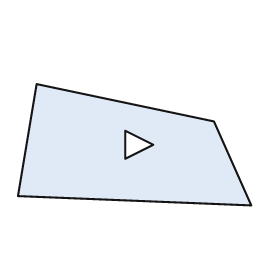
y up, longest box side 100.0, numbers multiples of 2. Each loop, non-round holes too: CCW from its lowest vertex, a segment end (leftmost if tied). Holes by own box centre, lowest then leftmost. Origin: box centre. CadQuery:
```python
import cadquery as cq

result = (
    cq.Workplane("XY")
    .moveTo(50.0, -26.0)
    .lineTo(34.0, 10.0)
    .lineTo(-42.0, 26.0)
    .lineTo(-50.0, -22.0)
    .close()
    .moveTo(-4.0, -6.0)
    .lineTo(8.0, 0.0)
    .lineTo(-4.0, 6.0)
    .close()
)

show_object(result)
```